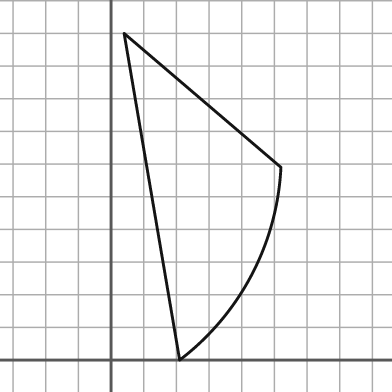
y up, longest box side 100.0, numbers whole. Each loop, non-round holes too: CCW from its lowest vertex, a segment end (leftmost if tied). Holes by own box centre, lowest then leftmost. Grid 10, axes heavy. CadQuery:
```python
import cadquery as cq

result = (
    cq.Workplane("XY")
    .moveTo(21.0, 0.0)
    .threePointArc((43.0, 26.0), (52.0, 59.0))
    .lineTo(4.0, 100.0)
    .close()
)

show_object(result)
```